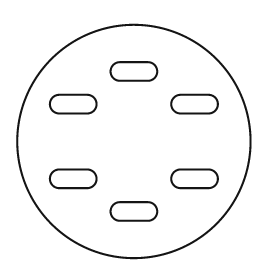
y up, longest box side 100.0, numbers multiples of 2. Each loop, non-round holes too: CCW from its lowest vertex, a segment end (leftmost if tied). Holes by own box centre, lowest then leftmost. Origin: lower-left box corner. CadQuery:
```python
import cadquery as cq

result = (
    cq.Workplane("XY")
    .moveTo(50.0, 50.0)
    .circle(50.0)
    .moveTo(44.0, 16.0)
    .lineTo(56.0, 16.0)
    .threePointArc((60.0, 20.0), (56.0, 24.0))
    .lineTo(44.0, 24.0)
    .threePointArc((40.0, 20.0), (44.0, 16.0))
    .close()
    .moveTo(18.0, 30.0)
    .lineTo(30.0, 30.0)
    .threePointArc((34.0, 34.0), (30.0, 38.0))
    .lineTo(18.0, 38.0)
    .threePointArc((14.0, 34.0), (18.0, 30.0))
    .close()
    .moveTo(70.0, 30.0)
    .lineTo(82.0, 30.0)
    .threePointArc((86.0, 34.0), (82.0, 38.0))
    .lineTo(70.0, 38.0)
    .threePointArc((66.0, 34.0), (70.0, 30.0))
    .close()
    .moveTo(18.0, 62.0)
    .lineTo(30.0, 62.0)
    .threePointArc((34.0, 66.0), (30.0, 70.0))
    .lineTo(18.0, 70.0)
    .threePointArc((14.0, 66.0), (18.0, 62.0))
    .close()
    .moveTo(70.0, 62.0)
    .lineTo(82.0, 62.0)
    .threePointArc((86.0, 66.0), (82.0, 70.0))
    .lineTo(70.0, 70.0)
    .threePointArc((66.0, 66.0), (70.0, 62.0))
    .close()
    .moveTo(44.0, 76.0)
    .lineTo(56.0, 76.0)
    .threePointArc((60.0, 80.0), (56.0, 84.0))
    .lineTo(44.0, 84.0)
    .threePointArc((40.0, 80.0), (44.0, 76.0))
    .close()
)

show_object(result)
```